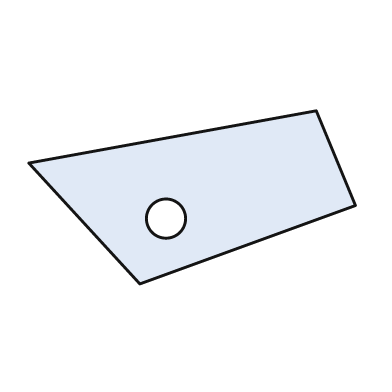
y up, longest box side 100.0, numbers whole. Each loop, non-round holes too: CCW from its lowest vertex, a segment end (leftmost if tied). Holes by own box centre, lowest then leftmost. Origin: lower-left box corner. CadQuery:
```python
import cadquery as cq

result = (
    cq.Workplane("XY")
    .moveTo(34.0, 0.0)
    .lineTo(100.0, 24.0)
    .lineTo(88.0, 53.0)
    .lineTo(0.0, 37.0)
    .close()
    .moveTo(42.0, 20.0)
    .circle(6.0)
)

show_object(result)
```